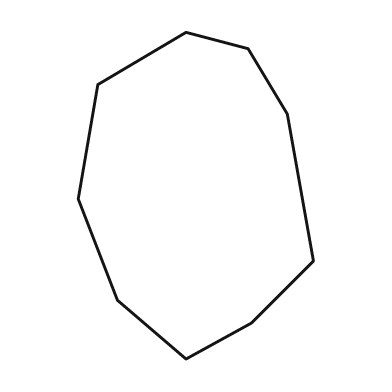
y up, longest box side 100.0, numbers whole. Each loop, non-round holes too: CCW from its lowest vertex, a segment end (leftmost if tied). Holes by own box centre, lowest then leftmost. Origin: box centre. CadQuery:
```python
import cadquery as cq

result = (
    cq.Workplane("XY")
    .moveTo(-3.0, -50.0)
    .lineTo(17.0, -39.0)
    .lineTo(36.0, -20.0)
    .lineTo(28.0, 25.0)
    .lineTo(16.0, 45.0)
    .lineTo(-3.0, 50.0)
    .lineTo(-30.0, 34.0)
    .lineTo(-36.0, -1.0)
    .lineTo(-24.0, -32.0)
    .close()
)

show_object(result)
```